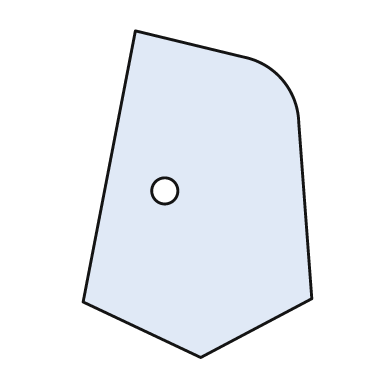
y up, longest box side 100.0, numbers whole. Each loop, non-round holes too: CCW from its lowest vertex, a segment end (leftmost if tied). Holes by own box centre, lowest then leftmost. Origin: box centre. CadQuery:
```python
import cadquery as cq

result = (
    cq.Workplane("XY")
    .moveTo(1.0, -50.0)
    .lineTo(35.0, -32.0)
    .lineTo(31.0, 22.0)
    .threePointArc((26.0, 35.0), (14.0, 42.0))
    .lineTo(-19.0, 50.0)
    .lineTo(-35.0, -33.0)
    .close()
    .moveTo(-10.0, 1.0)
    .circle(4.0)
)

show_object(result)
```